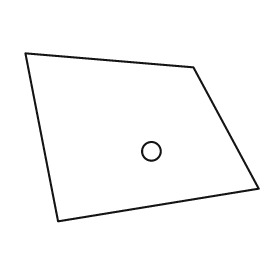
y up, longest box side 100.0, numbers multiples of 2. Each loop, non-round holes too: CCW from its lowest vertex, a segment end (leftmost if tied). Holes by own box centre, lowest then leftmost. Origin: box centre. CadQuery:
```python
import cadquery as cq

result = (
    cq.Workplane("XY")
    .moveTo(-36.0, -36.0)
    .lineTo(50.0, -22.0)
    .lineTo(22.0, 30.0)
    .lineTo(-50.0, 36.0)
    .close()
    .moveTo(4.0, -6.0)
    .circle(4.0)
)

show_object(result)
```